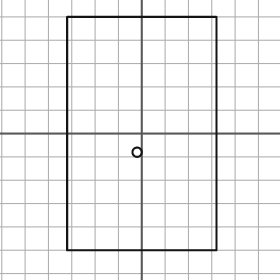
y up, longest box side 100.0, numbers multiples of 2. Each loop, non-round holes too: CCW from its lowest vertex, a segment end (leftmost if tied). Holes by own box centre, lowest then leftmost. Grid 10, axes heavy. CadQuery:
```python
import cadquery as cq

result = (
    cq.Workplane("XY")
    .moveTo(-32.0, -50.0)
    .lineTo(32.0, -50.0)
    .lineTo(32.0, 50.0)
    .lineTo(-32.0, 50.0)
    .close()
    .moveTo(-2.0, -8.0)
    .circle(2.0)
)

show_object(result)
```